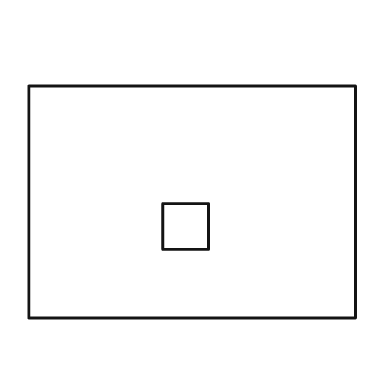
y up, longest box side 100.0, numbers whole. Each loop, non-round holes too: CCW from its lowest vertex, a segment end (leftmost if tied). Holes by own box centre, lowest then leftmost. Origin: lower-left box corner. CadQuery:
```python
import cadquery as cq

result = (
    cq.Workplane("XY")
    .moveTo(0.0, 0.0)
    .lineTo(100.0, 0.0)
    .lineTo(100.0, 71.0)
    .lineTo(0.0, 71.0)
    .close()
    .moveTo(41.0, 21.0)
    .lineTo(55.0, 21.0)
    .lineTo(55.0, 35.0)
    .lineTo(41.0, 35.0)
    .close()
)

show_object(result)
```